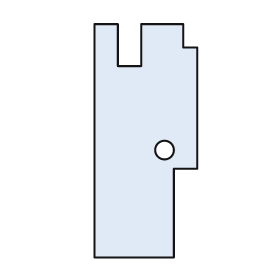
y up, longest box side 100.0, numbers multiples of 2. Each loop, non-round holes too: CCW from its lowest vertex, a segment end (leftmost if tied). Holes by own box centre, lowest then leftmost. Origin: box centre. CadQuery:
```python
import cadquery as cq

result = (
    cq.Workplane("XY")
    .moveTo(-22.0, -50.0)
    .lineTo(12.0, -50.0)
    .lineTo(12.0, -12.0)
    .lineTo(22.0, -12.0)
    .lineTo(22.0, 40.0)
    .lineTo(16.0, 40.0)
    .lineTo(16.0, 50.0)
    .lineTo(-2.0, 50.0)
    .lineTo(-2.0, 32.0)
    .lineTo(-12.0, 32.0)
    .lineTo(-12.0, 50.0)
    .lineTo(-22.0, 50.0)
    .close()
    .moveTo(8.0, -4.0)
    .circle(4.0)
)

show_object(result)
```